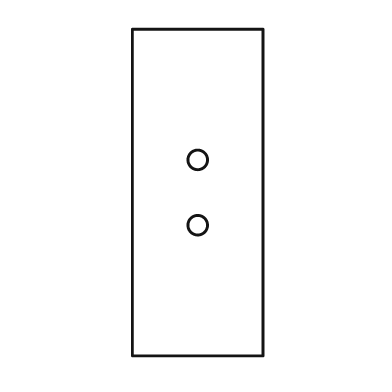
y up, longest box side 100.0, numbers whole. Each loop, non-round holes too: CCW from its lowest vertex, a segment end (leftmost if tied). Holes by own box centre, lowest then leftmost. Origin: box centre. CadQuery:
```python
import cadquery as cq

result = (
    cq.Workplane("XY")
    .moveTo(-20.0, -50.0)
    .lineTo(20.0, -50.0)
    .lineTo(20.0, 50.0)
    .lineTo(-20.0, 50.0)
    .close()
    .moveTo(0.0, -10.0)
    .circle(3.0)
    .moveTo(0.0, 10.0)
    .circle(3.0)
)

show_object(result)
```